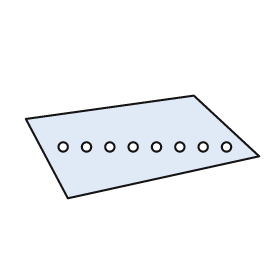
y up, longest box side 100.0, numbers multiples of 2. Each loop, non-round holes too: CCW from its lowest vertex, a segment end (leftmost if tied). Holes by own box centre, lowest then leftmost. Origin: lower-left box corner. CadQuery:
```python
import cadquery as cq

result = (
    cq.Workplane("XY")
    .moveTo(18.0, 0.0)
    .lineTo(100.0, 18.0)
    .lineTo(72.0, 44.0)
    .lineTo(0.0, 34.0)
    .close()
    .moveTo(16.0, 22.0)
    .circle(2.0)
    .moveTo(26.0, 22.0)
    .circle(2.0)
    .moveTo(36.0, 22.0)
    .circle(2.0)
    .moveTo(46.0, 22.0)
    .circle(2.0)
    .moveTo(56.0, 22.0)
    .circle(2.0)
    .moveTo(66.0, 22.0)
    .circle(2.0)
    .moveTo(76.0, 22.0)
    .circle(2.0)
    .moveTo(86.0, 22.0)
    .circle(2.0)
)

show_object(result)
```